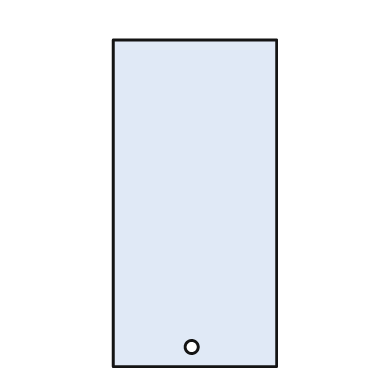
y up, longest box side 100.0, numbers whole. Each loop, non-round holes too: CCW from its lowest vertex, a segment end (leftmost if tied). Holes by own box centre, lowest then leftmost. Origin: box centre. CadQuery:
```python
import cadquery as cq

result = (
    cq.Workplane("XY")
    .moveTo(-25.0, -50.0)
    .lineTo(25.0, -50.0)
    .lineTo(25.0, 50.0)
    .lineTo(-25.0, 50.0)
    .close()
    .moveTo(-1.0, -44.0)
    .circle(2.0)
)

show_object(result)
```